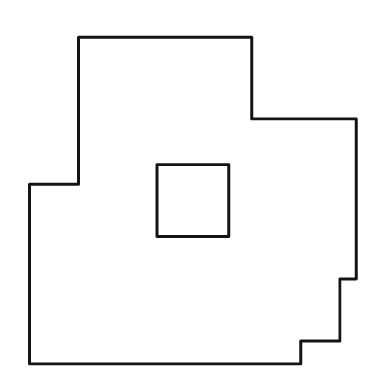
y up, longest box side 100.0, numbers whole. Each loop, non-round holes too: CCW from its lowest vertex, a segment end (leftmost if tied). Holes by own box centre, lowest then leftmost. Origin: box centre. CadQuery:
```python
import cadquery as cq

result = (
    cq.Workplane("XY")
    .moveTo(-50.0, -50.0)
    .lineTo(33.0, -50.0)
    .lineTo(33.0, -43.0)
    .lineTo(45.0, -43.0)
    .lineTo(45.0, -24.0)
    .lineTo(50.0, -24.0)
    .lineTo(50.0, 25.0)
    .lineTo(18.0, 25.0)
    .lineTo(18.0, 50.0)
    .lineTo(-35.0, 50.0)
    .lineTo(-35.0, 5.0)
    .lineTo(-50.0, 5.0)
    .close()
    .moveTo(-11.0, -11.0)
    .lineTo(11.0, -11.0)
    .lineTo(11.0, 11.0)
    .lineTo(-11.0, 11.0)
    .close()
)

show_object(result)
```